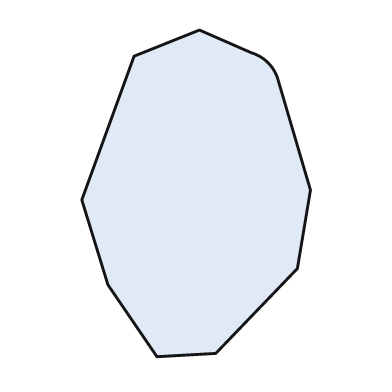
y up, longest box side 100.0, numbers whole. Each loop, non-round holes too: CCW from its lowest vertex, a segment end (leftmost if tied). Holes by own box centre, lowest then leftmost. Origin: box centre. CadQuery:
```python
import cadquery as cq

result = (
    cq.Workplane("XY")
    .moveTo(-12.0, -50.0)
    .lineTo(6.0, -49.0)
    .lineTo(31.0, -23.0)
    .lineTo(35.0, 1.0)
    .lineTo(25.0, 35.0)
    .threePointArc((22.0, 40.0), (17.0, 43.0))
    .lineTo(1.0, 50.0)
    .lineTo(-19.0, 42.0)
    .lineTo(-35.0, -2.0)
    .lineTo(-27.0, -28.0)
    .close()
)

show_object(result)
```